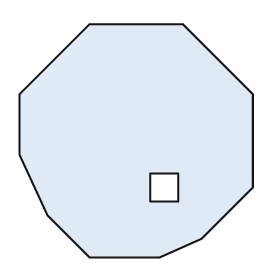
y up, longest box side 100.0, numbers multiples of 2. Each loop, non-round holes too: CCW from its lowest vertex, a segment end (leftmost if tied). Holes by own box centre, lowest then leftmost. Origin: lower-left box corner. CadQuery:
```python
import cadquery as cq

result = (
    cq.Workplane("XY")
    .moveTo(30.0, 0.0)
    .lineTo(60.0, 0.0)
    .lineTo(78.0, 8.0)
    .lineTo(100.0, 30.0)
    .lineTo(100.0, 70.0)
    .lineTo(70.0, 100.0)
    .lineTo(30.0, 100.0)
    .lineTo(0.0, 70.0)
    .lineTo(0.0, 44.0)
    .lineTo(12.0, 18.0)
    .close()
    .moveTo(56.0, 24.0)
    .lineTo(68.0, 24.0)
    .lineTo(68.0, 36.0)
    .lineTo(56.0, 36.0)
    .close()
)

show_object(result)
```